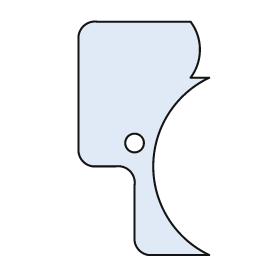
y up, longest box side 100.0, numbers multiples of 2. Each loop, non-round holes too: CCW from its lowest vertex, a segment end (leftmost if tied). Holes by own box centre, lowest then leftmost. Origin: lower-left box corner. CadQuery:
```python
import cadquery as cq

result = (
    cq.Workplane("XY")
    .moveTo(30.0, 0.0)
    .lineTo(56.0, 0.0)
    .threePointArc((32.0, 38.0), (56.0, 76.0))
    .lineTo(48.0, 76.0)
    .threePointArc((52.0, 88.0), (48.0, 100.0))
    .lineTo(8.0, 100.0)
    .threePointArc((2.0, 98.0), (0.0, 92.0))
    .lineTo(0.0, 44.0)
    .threePointArc((2.0, 40.0), (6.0, 38.0))
    .lineTo(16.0, 38.0)
    .threePointArc((22.0, 36.0), (24.0, 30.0))
    .lineTo(24.0, 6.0)
    .threePointArc((26.0, 2.0), (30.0, 0.0))
    .close()
    .moveTo(24.0, 48.0)
    .circle(4.0)
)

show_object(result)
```